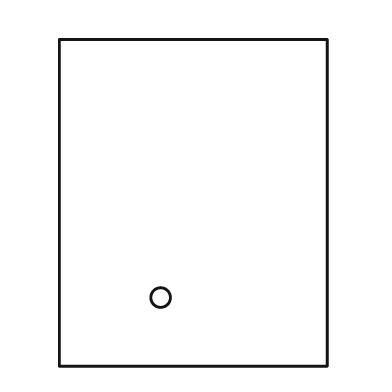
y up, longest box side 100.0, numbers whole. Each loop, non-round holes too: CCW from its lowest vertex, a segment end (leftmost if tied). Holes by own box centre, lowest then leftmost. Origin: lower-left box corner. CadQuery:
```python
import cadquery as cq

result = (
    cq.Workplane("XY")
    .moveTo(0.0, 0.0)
    .lineTo(82.0, 0.0)
    .lineTo(82.0, 100.0)
    .lineTo(0.0, 100.0)
    .close()
    .moveTo(31.0, 21.0)
    .circle(3.0)
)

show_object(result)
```